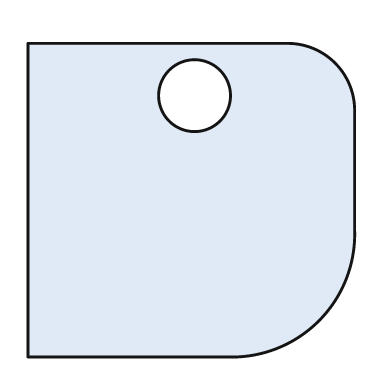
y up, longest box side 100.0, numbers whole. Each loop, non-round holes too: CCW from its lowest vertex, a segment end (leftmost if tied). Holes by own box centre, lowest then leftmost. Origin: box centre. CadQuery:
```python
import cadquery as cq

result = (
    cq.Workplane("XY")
    .moveTo(-50.0, -48.0)
    .lineTo(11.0, -48.0)
    .threePointArc((39.0, -37.0), (50.0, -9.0))
    .lineTo(50.0, 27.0)
    .threePointArc((44.0, 42.0), (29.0, 48.0))
    .lineTo(-50.0, 48.0)
    .close()
    .moveTo(1.0, 32.0)
    .circle(11.0)
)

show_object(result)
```